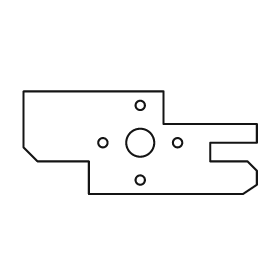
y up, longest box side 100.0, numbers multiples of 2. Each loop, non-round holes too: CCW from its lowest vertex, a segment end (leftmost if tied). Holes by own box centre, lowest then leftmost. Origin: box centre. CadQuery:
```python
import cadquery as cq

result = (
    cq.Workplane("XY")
    .moveTo(-22.0, -22.0)
    .lineTo(44.0, -22.0)
    .lineTo(50.0, -18.0)
    .lineTo(50.0, -12.0)
    .lineTo(46.0, -8.0)
    .lineTo(30.0, -8.0)
    .lineTo(30.0, 0.0)
    .lineTo(50.0, 0.0)
    .lineTo(50.0, 8.0)
    .lineTo(10.0, 8.0)
    .lineTo(10.0, 22.0)
    .lineTo(-50.0, 22.0)
    .lineTo(-50.0, -2.0)
    .lineTo(-44.0, -8.0)
    .lineTo(-22.0, -8.0)
    .close()
    .moveTo(0.0, -16.0)
    .circle(2.0)
    .moveTo(-16.0, 0.0)
    .circle(2.0)
    .moveTo(0.0, 0.0)
    .circle(6.0)
    .moveTo(16.0, 0.0)
    .circle(2.0)
    .moveTo(0.0, 16.0)
    .circle(2.0)
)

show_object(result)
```